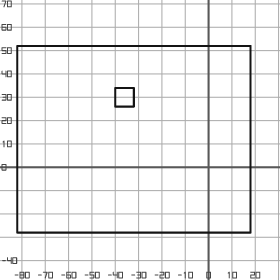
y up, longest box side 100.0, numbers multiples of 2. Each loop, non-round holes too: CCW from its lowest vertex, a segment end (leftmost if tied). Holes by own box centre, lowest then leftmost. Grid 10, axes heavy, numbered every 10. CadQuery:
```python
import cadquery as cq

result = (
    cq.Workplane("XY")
    .moveTo(-82.0, -28.0)
    .lineTo(18.0, -28.0)
    .lineTo(18.0, 52.0)
    .lineTo(-82.0, 52.0)
    .close()
    .moveTo(-40.0, 26.0)
    .lineTo(-32.0, 26.0)
    .lineTo(-32.0, 34.0)
    .lineTo(-40.0, 34.0)
    .close()
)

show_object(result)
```